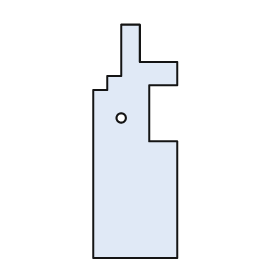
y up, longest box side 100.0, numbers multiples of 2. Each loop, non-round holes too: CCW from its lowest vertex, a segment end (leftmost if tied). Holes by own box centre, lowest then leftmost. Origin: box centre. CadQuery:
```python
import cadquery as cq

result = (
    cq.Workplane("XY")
    .moveTo(-18.0, -50.0)
    .lineTo(18.0, -50.0)
    .lineTo(18.0, 0.0)
    .lineTo(6.0, 0.0)
    .lineTo(6.0, 24.0)
    .lineTo(18.0, 24.0)
    .lineTo(18.0, 34.0)
    .lineTo(2.0, 34.0)
    .lineTo(2.0, 50.0)
    .lineTo(-6.0, 50.0)
    .lineTo(-6.0, 28.0)
    .lineTo(-12.0, 28.0)
    .lineTo(-12.0, 22.0)
    .lineTo(-18.0, 22.0)
    .close()
    .moveTo(-6.0, 10.0)
    .circle(2.0)
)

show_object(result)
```